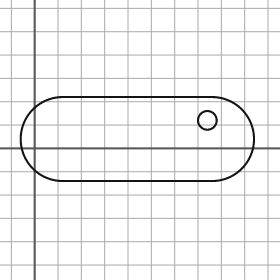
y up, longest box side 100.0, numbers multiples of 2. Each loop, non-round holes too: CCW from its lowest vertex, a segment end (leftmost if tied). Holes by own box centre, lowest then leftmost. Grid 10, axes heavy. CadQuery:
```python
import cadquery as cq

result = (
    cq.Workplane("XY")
    .moveTo(12.0, -14.0)
    .lineTo(76.0, -14.0)
    .threePointArc((94.0, 4.0), (76.0, 22.0))
    .lineTo(12.0, 22.0)
    .threePointArc((-6.0, 4.0), (12.0, -14.0))
    .close()
    .moveTo(74.0, 12.0)
    .circle(4.0)
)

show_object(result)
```